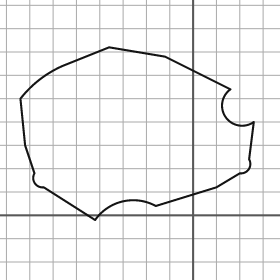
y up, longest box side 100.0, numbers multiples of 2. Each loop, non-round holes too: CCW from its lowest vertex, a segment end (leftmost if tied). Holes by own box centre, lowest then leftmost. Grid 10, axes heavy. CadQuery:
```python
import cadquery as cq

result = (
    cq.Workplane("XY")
    .moveTo(-42.0, -2.0)
    .threePointArc((-30.0, 6.0), (-16.0, 4.0))
    .lineTo(10.0, 12.0)
    .lineTo(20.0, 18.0)
    .threePointArc((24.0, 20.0), (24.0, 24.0))
    .lineTo(26.0, 40.0)
    .threePointArc((14.0, 42.0), (16.0, 54.0))
    .lineTo(-12.0, 68.0)
    .lineTo(-36.0, 72.0)
    .lineTo(-56.0, 64.0)
    .threePointArc((-66.0, 58.0), (-74.0, 50.0))
    .lineTo(-72.0, 30.0)
    .lineTo(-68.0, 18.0)
    .threePointArc((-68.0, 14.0), (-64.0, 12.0))
    .close()
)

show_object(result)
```